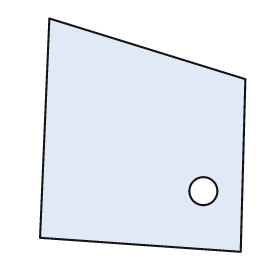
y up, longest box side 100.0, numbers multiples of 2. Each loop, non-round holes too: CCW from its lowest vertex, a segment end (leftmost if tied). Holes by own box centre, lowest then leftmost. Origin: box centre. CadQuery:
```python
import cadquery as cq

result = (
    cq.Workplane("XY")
    .moveTo(42.0, -50.0)
    .lineTo(44.0, 24.0)
    .lineTo(-40.0, 50.0)
    .lineTo(-44.0, -44.0)
    .close()
    .moveTo(26.0, -24.0)
    .circle(6.0)
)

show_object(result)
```